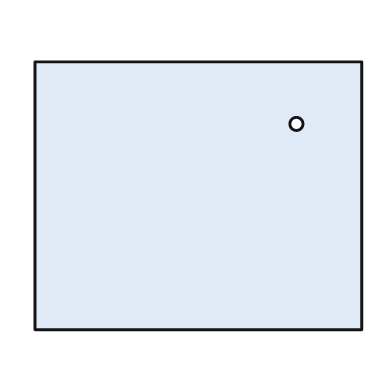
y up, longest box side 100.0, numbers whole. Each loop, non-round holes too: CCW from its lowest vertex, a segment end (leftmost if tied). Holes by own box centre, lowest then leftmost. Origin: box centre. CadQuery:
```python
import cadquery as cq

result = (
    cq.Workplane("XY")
    .moveTo(-50.0, -41.0)
    .lineTo(50.0, -41.0)
    .lineTo(50.0, 41.0)
    .lineTo(-50.0, 41.0)
    .close()
    .moveTo(30.0, 22.0)
    .circle(2.0)
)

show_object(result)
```